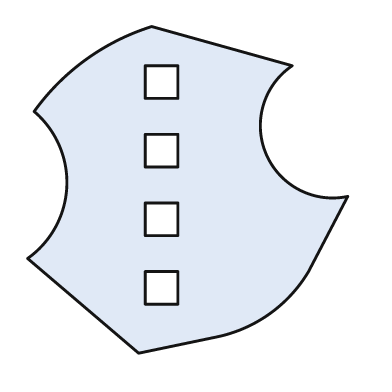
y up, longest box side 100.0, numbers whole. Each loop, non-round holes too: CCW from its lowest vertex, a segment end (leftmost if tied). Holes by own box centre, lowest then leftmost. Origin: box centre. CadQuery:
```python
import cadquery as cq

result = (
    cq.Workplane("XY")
    .moveTo(-15.0, -50.0)
    .lineTo(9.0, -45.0)
    .threePointArc((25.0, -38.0), (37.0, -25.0))
    .lineTo(49.0, -2.0)
    .threePointArc((24.0, 11.0), (32.0, 38.0))
    .lineTo(-11.0, 50.0)
    .threePointArc((-31.0, 40.0), (-47.0, 24.0))
    .threePointArc((-37.0, 1.0), (-49.0, -21.0))
    .close()
    .moveTo(-13.0, -35.0)
    .lineTo(-3.0, -35.0)
    .lineTo(-3.0, -25.0)
    .lineTo(-13.0, -25.0)
    .close()
    .moveTo(-13.0, -14.0)
    .lineTo(-3.0, -14.0)
    .lineTo(-3.0, -4.0)
    .lineTo(-13.0, -4.0)
    .close()
    .moveTo(-13.0, 7.0)
    .lineTo(-3.0, 7.0)
    .lineTo(-3.0, 17.0)
    .lineTo(-13.0, 17.0)
    .close()
    .moveTo(-13.0, 28.0)
    .lineTo(-3.0, 28.0)
    .lineTo(-3.0, 38.0)
    .lineTo(-13.0, 38.0)
    .close()
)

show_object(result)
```